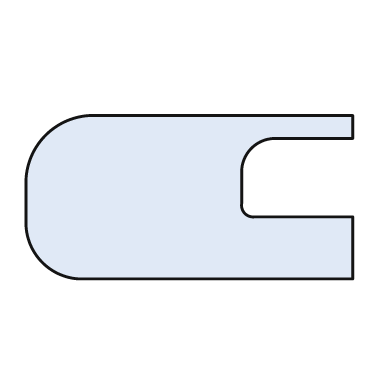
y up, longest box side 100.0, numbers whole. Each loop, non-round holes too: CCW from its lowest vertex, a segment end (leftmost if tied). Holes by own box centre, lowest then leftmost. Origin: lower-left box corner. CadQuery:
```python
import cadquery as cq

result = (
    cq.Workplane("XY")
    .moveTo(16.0, 0.0)
    .lineTo(100.0, 0.0)
    .lineTo(100.0, 19.0)
    .lineTo(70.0, 19.0)
    .threePointArc((67.0, 20.0), (66.0, 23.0))
    .lineTo(66.0, 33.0)
    .threePointArc((69.0, 40.0), (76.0, 43.0))
    .lineTo(100.0, 43.0)
    .lineTo(100.0, 50.0)
    .lineTo(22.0, 50.0)
    .threePointArc((6.0, 44.0), (0.0, 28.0))
    .lineTo(0.0, 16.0)
    .threePointArc((5.0, 5.0), (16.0, 0.0))
    .close()
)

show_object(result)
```